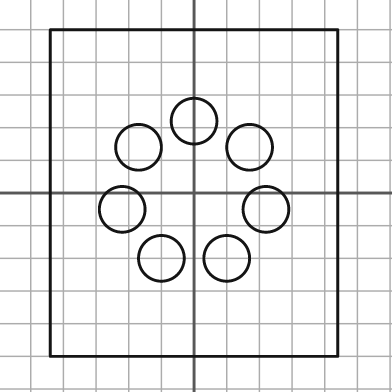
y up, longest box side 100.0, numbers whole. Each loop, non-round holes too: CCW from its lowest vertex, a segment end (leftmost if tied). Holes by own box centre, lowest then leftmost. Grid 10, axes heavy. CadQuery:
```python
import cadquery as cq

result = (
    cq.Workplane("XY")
    .moveTo(-44.0, -50.0)
    .lineTo(44.0, -50.0)
    .lineTo(44.0, 50.0)
    .lineTo(-44.0, 50.0)
    .close()
    .moveTo(-10.0, -20.0)
    .circle(7.0)
    .moveTo(10.0, -20.0)
    .circle(7.0)
    .moveTo(-22.0, -5.0)
    .circle(7.0)
    .moveTo(22.0, -5.0)
    .circle(7.0)
    .moveTo(-17.0, 14.0)
    .circle(7.0)
    .moveTo(17.0, 14.0)
    .circle(7.0)
    .moveTo(0.0, 22.0)
    .circle(7.0)
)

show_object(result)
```